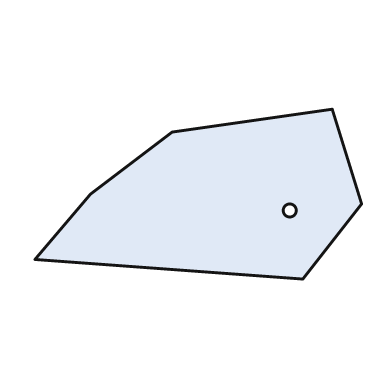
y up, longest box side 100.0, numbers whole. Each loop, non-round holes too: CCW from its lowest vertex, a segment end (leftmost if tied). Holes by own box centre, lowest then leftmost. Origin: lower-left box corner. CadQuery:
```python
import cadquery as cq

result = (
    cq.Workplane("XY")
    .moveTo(82.0, 0.0)
    .lineTo(100.0, 23.0)
    .lineTo(91.0, 52.0)
    .lineTo(42.0, 45.0)
    .lineTo(17.0, 26.0)
    .lineTo(0.0, 6.0)
    .close()
    .moveTo(78.0, 21.0)
    .circle(2.0)
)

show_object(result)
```